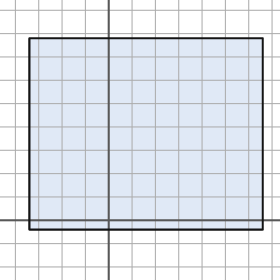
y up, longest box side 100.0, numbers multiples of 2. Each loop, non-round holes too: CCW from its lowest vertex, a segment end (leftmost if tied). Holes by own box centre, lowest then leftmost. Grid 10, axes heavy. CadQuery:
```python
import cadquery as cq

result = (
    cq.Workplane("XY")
    .moveTo(-34.0, -4.0)
    .lineTo(66.0, -4.0)
    .lineTo(66.0, 78.0)
    .lineTo(-34.0, 78.0)
    .close()
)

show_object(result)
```